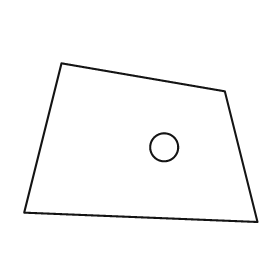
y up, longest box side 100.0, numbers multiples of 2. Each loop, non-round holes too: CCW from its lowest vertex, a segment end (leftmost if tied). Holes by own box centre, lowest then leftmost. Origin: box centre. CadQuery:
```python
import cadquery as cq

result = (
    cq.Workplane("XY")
    .moveTo(50.0, -34.0)
    .lineTo(36.0, 22.0)
    .lineTo(-34.0, 34.0)
    .lineTo(-50.0, -30.0)
    .close()
    .moveTo(10.0, -2.0)
    .circle(6.0)
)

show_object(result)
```